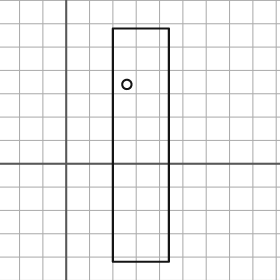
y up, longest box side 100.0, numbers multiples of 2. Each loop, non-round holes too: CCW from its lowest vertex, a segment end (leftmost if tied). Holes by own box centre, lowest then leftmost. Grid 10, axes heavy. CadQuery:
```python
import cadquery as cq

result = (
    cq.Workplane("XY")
    .moveTo(20.0, -42.0)
    .lineTo(44.0, -42.0)
    .lineTo(44.0, 58.0)
    .lineTo(20.0, 58.0)
    .close()
    .moveTo(26.0, 34.0)
    .circle(2.0)
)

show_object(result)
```